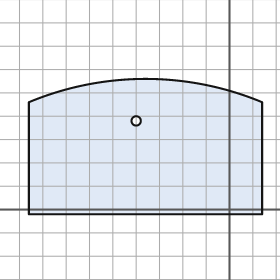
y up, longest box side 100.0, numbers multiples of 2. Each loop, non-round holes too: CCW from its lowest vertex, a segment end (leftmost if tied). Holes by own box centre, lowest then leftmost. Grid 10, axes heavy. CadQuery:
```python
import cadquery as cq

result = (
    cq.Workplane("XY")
    .moveTo(-86.0, -2.0)
    .lineTo(14.0, -2.0)
    .lineTo(14.0, 46.0)
    .threePointArc((-36.0, 56.0), (-86.0, 46.0))
    .close()
    .moveTo(-40.0, 38.0)
    .circle(2.0)
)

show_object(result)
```